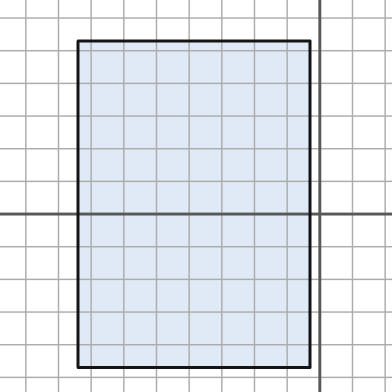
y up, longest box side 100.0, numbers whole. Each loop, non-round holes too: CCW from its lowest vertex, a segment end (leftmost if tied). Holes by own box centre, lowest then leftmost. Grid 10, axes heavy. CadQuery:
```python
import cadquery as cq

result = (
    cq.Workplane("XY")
    .moveTo(-74.0, -47.0)
    .lineTo(-3.0, -47.0)
    .lineTo(-3.0, 53.0)
    .lineTo(-74.0, 53.0)
    .close()
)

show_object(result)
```